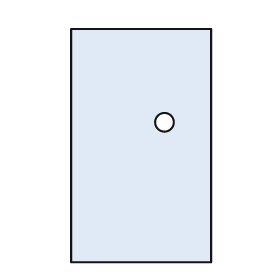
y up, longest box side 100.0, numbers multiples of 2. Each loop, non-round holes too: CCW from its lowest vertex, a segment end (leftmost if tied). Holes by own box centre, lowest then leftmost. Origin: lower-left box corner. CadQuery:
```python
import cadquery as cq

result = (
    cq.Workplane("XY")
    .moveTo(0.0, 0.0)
    .lineTo(60.0, 0.0)
    .lineTo(60.0, 100.0)
    .lineTo(0.0, 100.0)
    .close()
    .moveTo(40.0, 60.0)
    .circle(4.0)
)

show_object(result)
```